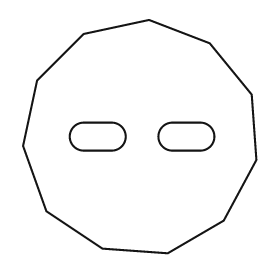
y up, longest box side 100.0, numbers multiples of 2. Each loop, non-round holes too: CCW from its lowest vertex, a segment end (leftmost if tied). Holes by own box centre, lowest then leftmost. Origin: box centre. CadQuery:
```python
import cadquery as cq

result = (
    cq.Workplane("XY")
    .moveTo(12.0, -50.0)
    .lineTo(36.0, -36.0)
    .lineTo(50.0, -10.0)
    .lineTo(48.0, 18.0)
    .lineTo(30.0, 40.0)
    .lineTo(4.0, 50.0)
    .lineTo(-24.0, 44.0)
    .lineTo(-44.0, 24.0)
    .lineTo(-50.0, -4.0)
    .lineTo(-40.0, -32.0)
    .lineTo(-16.0, -48.0)
    .close()
    .moveTo(-24.0, -6.0)
    .lineTo(-12.0, -6.0)
    .threePointArc((-6.0, 0.0), (-12.0, 6.0))
    .lineTo(-24.0, 6.0)
    .threePointArc((-30.0, 0.0), (-24.0, -6.0))
    .close()
    .moveTo(14.0, -6.0)
    .lineTo(26.0, -6.0)
    .threePointArc((32.0, 0.0), (26.0, 6.0))
    .lineTo(14.0, 6.0)
    .threePointArc((8.0, 0.0), (14.0, -6.0))
    .close()
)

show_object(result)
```